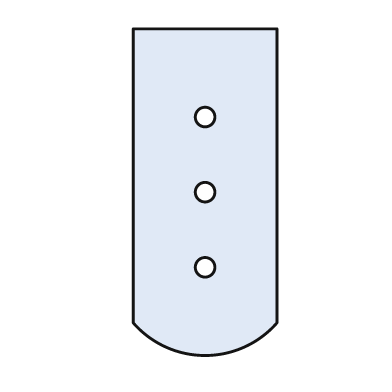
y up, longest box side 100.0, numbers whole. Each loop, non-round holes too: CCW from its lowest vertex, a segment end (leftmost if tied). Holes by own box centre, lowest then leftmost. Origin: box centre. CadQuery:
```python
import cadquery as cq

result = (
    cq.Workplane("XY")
    .moveTo(-22.0, -40.0)
    .threePointArc((0.0, -50.0), (22.0, -40.0))
    .lineTo(22.0, 50.0)
    .lineTo(-22.0, 50.0)
    .close()
    .moveTo(0.0, -23.0)
    .circle(3.0)
    .moveTo(0.0, 0.0)
    .circle(3.0)
    .moveTo(0.0, 23.0)
    .circle(3.0)
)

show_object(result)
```